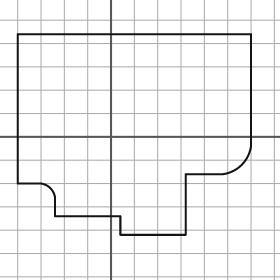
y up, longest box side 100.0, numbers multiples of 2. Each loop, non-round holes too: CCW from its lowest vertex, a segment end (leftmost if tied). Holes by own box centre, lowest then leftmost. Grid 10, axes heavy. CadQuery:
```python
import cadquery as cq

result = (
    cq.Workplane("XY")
    .moveTo(4.0, -42.0)
    .lineTo(32.0, -42.0)
    .lineTo(32.0, -16.0)
    .lineTo(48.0, -16.0)
    .threePointArc((56.0, -12.0), (60.0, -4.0))
    .lineTo(60.0, 44.0)
    .lineTo(-40.0, 44.0)
    .lineTo(-40.0, -20.0)
    .lineTo(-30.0, -20.0)
    .threePointArc((-26.0, -22.0), (-24.0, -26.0))
    .lineTo(-24.0, -34.0)
    .lineTo(4.0, -34.0)
    .close()
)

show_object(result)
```